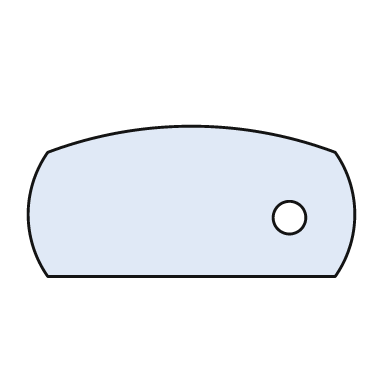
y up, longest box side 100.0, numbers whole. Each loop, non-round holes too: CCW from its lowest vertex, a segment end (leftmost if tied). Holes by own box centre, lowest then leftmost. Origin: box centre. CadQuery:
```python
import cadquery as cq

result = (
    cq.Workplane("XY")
    .moveTo(-44.0, -23.0)
    .lineTo(44.0, -23.0)
    .threePointArc((50.0, -4.0), (44.0, 15.0))
    .threePointArc((0.0, 23.0), (-44.0, 15.0))
    .threePointArc((-50.0, -4.0), (-44.0, -23.0))
    .close()
    .moveTo(30.0, -5.0)
    .circle(5.0)
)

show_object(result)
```